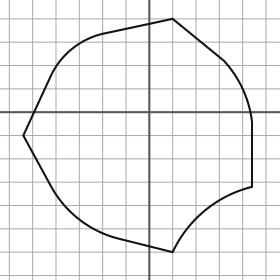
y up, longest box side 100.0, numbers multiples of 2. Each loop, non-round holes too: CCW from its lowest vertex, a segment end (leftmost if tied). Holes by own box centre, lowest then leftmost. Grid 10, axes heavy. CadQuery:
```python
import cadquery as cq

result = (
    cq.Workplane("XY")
    .moveTo(10.0, -60.0)
    .threePointArc((24.0, -42.0), (44.0, -32.0))
    .lineTo(44.0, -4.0)
    .threePointArc((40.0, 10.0), (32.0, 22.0))
    .lineTo(10.0, 40.0)
    .lineTo(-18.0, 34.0)
    .threePointArc((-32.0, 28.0), (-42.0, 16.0))
    .lineTo(-54.0, -10.0)
    .lineTo(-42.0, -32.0)
    .threePointArc((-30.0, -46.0), (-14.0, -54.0))
    .close()
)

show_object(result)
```